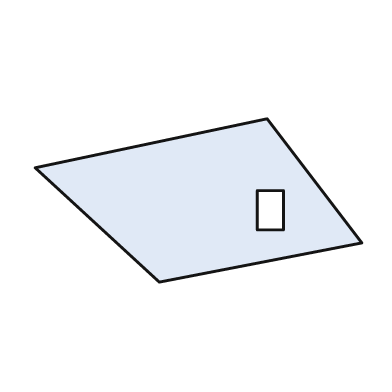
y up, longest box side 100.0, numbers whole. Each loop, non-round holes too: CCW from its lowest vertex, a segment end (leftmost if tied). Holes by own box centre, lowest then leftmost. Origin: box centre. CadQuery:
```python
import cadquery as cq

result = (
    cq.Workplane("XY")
    .moveTo(-12.0, -25.0)
    .lineTo(50.0, -13.0)
    .lineTo(21.0, 25.0)
    .lineTo(-50.0, 10.0)
    .close()
    .moveTo(18.0, -9.0)
    .lineTo(26.0, -9.0)
    .lineTo(26.0, 3.0)
    .lineTo(18.0, 3.0)
    .close()
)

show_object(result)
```